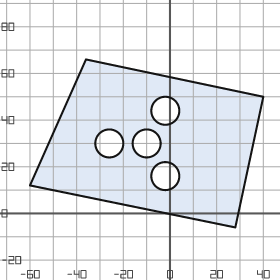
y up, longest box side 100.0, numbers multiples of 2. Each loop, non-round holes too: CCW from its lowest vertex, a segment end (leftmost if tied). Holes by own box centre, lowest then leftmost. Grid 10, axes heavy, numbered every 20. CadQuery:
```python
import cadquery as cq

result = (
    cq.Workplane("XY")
    .moveTo(28.0, -6.0)
    .lineTo(40.0, 50.0)
    .lineTo(-36.0, 66.0)
    .lineTo(-60.0, 12.0)
    .close()
    .moveTo(-2.0, 16.0)
    .circle(6.0)
    .moveTo(-26.0, 30.0)
    .circle(6.0)
    .moveTo(-10.0, 30.0)
    .circle(6.0)
    .moveTo(-2.0, 44.0)
    .circle(6.0)
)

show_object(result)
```